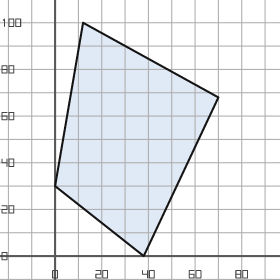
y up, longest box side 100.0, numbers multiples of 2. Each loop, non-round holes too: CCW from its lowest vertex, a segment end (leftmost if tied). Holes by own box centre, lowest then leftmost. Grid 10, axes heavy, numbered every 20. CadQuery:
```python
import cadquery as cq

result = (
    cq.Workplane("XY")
    .moveTo(38.0, 0.0)
    .lineTo(70.0, 68.0)
    .lineTo(12.0, 100.0)
    .lineTo(0.0, 30.0)
    .close()
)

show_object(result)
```